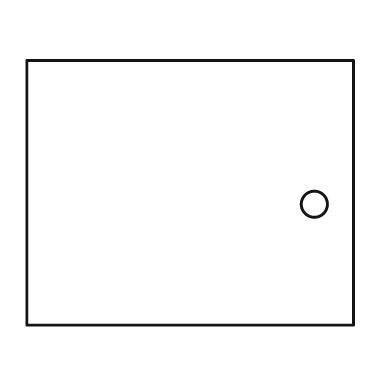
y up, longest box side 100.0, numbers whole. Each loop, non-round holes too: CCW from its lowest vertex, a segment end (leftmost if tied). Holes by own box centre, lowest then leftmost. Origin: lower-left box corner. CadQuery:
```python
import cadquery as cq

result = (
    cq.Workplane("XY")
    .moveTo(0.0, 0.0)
    .lineTo(100.0, 0.0)
    .lineTo(100.0, 81.0)
    .lineTo(0.0, 81.0)
    .close()
    .moveTo(88.0, 37.0)
    .circle(4.0)
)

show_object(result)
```